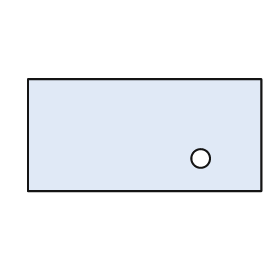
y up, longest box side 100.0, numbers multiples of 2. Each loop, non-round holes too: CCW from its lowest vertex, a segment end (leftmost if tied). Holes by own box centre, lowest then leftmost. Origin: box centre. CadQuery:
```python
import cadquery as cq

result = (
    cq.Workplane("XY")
    .moveTo(-50.0, -24.0)
    .lineTo(50.0, -24.0)
    .lineTo(50.0, 24.0)
    .lineTo(-50.0, 24.0)
    .close()
    .moveTo(24.0, -10.0)
    .circle(4.0)
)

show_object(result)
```